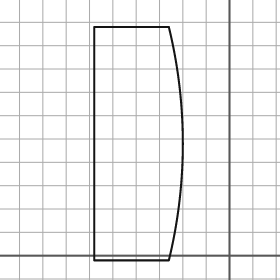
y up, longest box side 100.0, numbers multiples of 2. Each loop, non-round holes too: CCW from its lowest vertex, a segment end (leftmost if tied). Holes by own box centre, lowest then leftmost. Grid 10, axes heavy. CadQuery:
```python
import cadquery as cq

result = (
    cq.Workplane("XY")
    .moveTo(-58.0, -2.0)
    .lineTo(-26.0, -2.0)
    .threePointArc((-20.0, 48.0), (-26.0, 98.0))
    .lineTo(-58.0, 98.0)
    .close()
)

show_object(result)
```